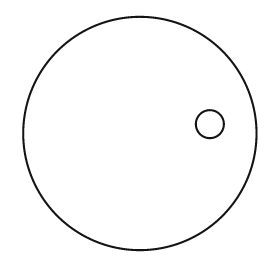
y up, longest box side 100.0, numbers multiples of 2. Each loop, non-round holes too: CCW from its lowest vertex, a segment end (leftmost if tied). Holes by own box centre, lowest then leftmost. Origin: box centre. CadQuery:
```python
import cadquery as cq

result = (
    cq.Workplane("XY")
    .moveTo(0.0, 0.0)
    .circle(50.0)
    .moveTo(30.0, 4.0)
    .circle(6.0)
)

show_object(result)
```